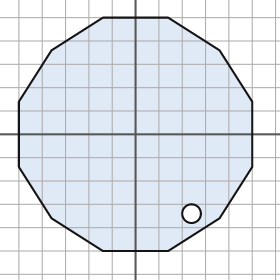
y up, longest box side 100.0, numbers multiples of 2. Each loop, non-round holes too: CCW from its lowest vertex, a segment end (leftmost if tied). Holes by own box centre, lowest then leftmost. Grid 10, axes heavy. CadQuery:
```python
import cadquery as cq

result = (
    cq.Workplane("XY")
    .moveTo(-14.0, -50.0)
    .lineTo(14.0, -50.0)
    .lineTo(36.0, -36.0)
    .lineTo(50.0, -14.0)
    .lineTo(50.0, 14.0)
    .lineTo(36.0, 36.0)
    .lineTo(14.0, 50.0)
    .lineTo(-14.0, 50.0)
    .lineTo(-36.0, 36.0)
    .lineTo(-50.0, 14.0)
    .lineTo(-50.0, -14.0)
    .lineTo(-36.0, -36.0)
    .close()
    .moveTo(24.0, -34.0)
    .circle(4.0)
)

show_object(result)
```